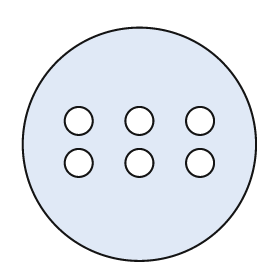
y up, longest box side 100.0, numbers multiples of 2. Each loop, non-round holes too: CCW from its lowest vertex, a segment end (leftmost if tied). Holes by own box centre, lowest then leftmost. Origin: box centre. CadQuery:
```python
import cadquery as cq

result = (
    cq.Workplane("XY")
    .moveTo(0.0, 0.0)
    .circle(50.0)
    .moveTo(-26.0, -8.0)
    .circle(6.0)
    .moveTo(0.0, -8.0)
    .circle(6.0)
    .moveTo(26.0, -8.0)
    .circle(6.0)
    .moveTo(-26.0, 10.0)
    .circle(6.0)
    .moveTo(0.0, 10.0)
    .circle(6.0)
    .moveTo(26.0, 10.0)
    .circle(6.0)
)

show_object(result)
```